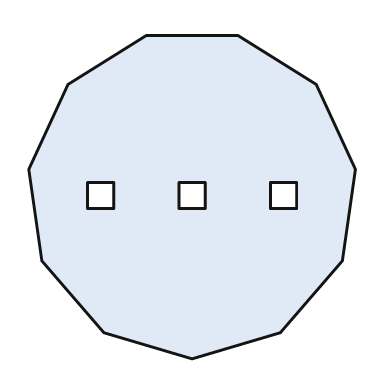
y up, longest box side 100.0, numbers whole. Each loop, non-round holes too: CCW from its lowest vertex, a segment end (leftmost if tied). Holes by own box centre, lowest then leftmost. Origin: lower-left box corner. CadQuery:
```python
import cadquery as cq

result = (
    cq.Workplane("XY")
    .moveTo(50.0, 0.0)
    .lineTo(77.0, 8.0)
    .lineTo(96.0, 30.0)
    .lineTo(100.0, 58.0)
    .lineTo(88.0, 84.0)
    .lineTo(64.0, 99.0)
    .lineTo(36.0, 99.0)
    .lineTo(12.0, 84.0)
    .lineTo(0.0, 58.0)
    .lineTo(4.0, 30.0)
    .lineTo(23.0, 8.0)
    .close()
    .moveTo(18.0, 46.0)
    .lineTo(26.0, 46.0)
    .lineTo(26.0, 54.0)
    .lineTo(18.0, 54.0)
    .close()
    .moveTo(46.0, 46.0)
    .lineTo(54.0, 46.0)
    .lineTo(54.0, 54.0)
    .lineTo(46.0, 54.0)
    .close()
    .moveTo(74.0, 46.0)
    .lineTo(82.0, 46.0)
    .lineTo(82.0, 54.0)
    .lineTo(74.0, 54.0)
    .close()
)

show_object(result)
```